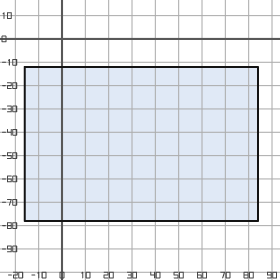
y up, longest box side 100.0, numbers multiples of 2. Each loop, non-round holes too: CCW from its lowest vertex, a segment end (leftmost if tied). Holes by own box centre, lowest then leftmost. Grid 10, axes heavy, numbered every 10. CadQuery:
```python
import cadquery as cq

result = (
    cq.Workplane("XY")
    .moveTo(-16.0, -78.0)
    .lineTo(84.0, -78.0)
    .lineTo(84.0, -12.0)
    .lineTo(-16.0, -12.0)
    .close()
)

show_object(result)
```